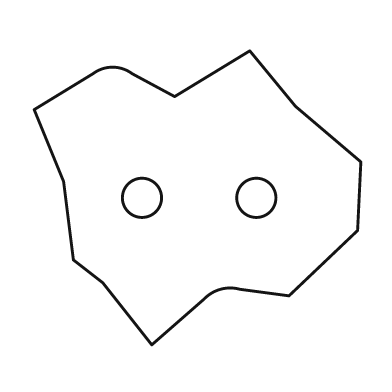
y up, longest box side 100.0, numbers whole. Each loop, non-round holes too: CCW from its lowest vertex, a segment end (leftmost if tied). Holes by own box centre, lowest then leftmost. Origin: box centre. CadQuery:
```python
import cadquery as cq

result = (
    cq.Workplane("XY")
    .moveTo(-14.0, -45.0)
    .lineTo(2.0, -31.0)
    .threePointArc((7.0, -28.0), (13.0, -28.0))
    .lineTo(28.0, -30.0)
    .lineTo(49.0, -10.0)
    .lineTo(50.0, 11.0)
    .lineTo(30.0, 28.0)
    .lineTo(16.0, 45.0)
    .lineTo(-7.0, 31.0)
    .lineTo(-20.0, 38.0)
    .threePointArc((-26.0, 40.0), (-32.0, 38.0))
    .lineTo(-50.0, 27.0)
    .lineTo(-41.0, 5.0)
    .lineTo(-38.0, -19.0)
    .lineTo(-29.0, -26.0)
    .close()
    .moveTo(-17.0, 0.0)
    .circle(6.0)
    .moveTo(18.0, 0.0)
    .circle(6.0)
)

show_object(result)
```